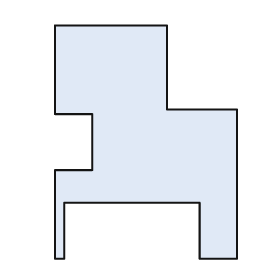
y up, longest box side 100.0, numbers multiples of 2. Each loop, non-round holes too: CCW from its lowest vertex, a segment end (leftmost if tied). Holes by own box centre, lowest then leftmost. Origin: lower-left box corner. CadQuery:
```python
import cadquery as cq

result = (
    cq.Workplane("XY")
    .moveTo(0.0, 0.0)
    .lineTo(4.0, 0.0)
    .lineTo(4.0, 24.0)
    .lineTo(62.0, 24.0)
    .lineTo(62.0, 0.0)
    .lineTo(78.0, 0.0)
    .lineTo(78.0, 64.0)
    .lineTo(48.0, 64.0)
    .lineTo(48.0, 100.0)
    .lineTo(0.0, 100.0)
    .lineTo(0.0, 62.0)
    .lineTo(16.0, 62.0)
    .lineTo(16.0, 38.0)
    .lineTo(0.0, 38.0)
    .close()
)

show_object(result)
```